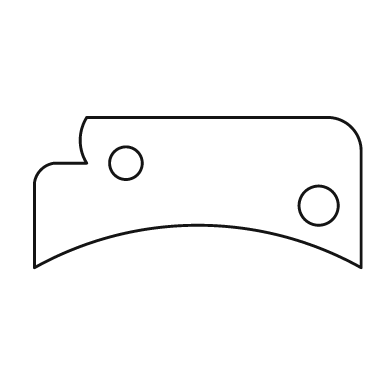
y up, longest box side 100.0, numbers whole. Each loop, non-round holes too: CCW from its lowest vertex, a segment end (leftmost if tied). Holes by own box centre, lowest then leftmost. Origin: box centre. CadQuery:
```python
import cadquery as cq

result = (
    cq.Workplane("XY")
    .moveTo(-50.0, -23.0)
    .threePointArc((0.0, -10.0), (50.0, -23.0))
    .lineTo(50.0, 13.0)
    .threePointArc((47.0, 20.0), (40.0, 23.0))
    .lineTo(-34.0, 23.0)
    .threePointArc((-36.0, 16.0), (-34.0, 9.0))
    .lineTo(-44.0, 9.0)
    .threePointArc((-48.0, 7.0), (-50.0, 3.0))
    .close()
    .moveTo(37.0, -4.0)
    .circle(6.0)
    .moveTo(-22.0, 9.0)
    .circle(5.0)
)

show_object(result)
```